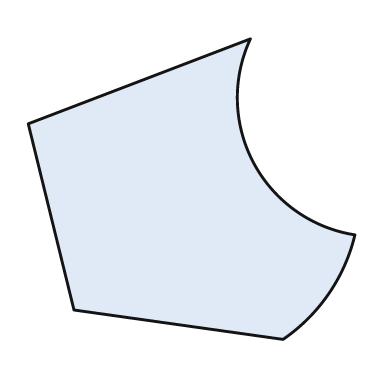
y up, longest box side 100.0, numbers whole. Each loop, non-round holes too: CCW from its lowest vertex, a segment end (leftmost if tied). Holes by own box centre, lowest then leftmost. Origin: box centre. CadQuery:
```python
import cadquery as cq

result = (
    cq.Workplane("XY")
    .moveTo(28.0, -46.0)
    .threePointArc((42.0, -32.0), (50.0, -14.0))
    .threePointArc((19.0, 8.0), (18.0, 46.0))
    .lineTo(-50.0, 20.0)
    .lineTo(-36.0, -37.0)
    .close()
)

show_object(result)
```